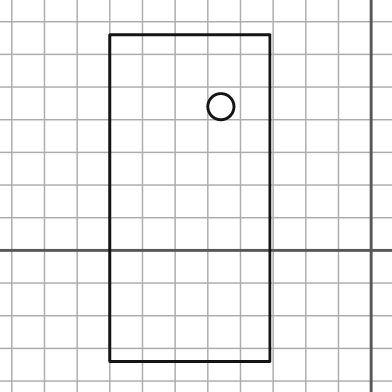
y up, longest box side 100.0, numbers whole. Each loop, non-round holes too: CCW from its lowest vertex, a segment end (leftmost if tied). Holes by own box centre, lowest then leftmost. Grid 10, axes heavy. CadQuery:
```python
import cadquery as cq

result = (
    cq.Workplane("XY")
    .moveTo(-80.0, -34.0)
    .lineTo(-31.0, -34.0)
    .lineTo(-31.0, 66.0)
    .lineTo(-80.0, 66.0)
    .close()
    .moveTo(-46.0, 44.0)
    .circle(4.0)
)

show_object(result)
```